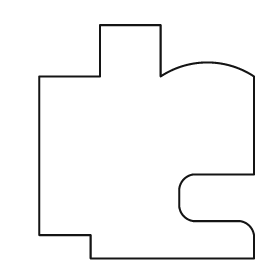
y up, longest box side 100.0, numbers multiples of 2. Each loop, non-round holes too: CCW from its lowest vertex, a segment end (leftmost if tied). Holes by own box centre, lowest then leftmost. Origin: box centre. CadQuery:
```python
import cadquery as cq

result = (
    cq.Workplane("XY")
    .moveTo(-24.0, -50.0)
    .lineTo(46.0, -50.0)
    .lineTo(46.0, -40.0)
    .threePointArc((44.0, -36.0), (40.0, -34.0))
    .lineTo(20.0, -34.0)
    .threePointArc((16.0, -32.0), (14.0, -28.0))
    .lineTo(14.0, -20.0)
    .threePointArc((16.0, -16.0), (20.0, -14.0))
    .lineTo(46.0, -14.0)
    .lineTo(46.0, 28.0)
    .threePointArc((26.0, 34.0), (6.0, 28.0))
    .lineTo(6.0, 50.0)
    .lineTo(-20.0, 50.0)
    .lineTo(-20.0, 28.0)
    .lineTo(-46.0, 28.0)
    .lineTo(-46.0, -40.0)
    .lineTo(-24.0, -40.0)
    .close()
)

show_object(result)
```